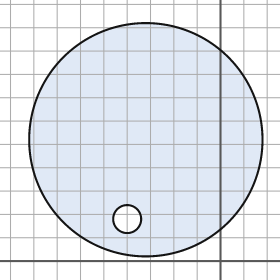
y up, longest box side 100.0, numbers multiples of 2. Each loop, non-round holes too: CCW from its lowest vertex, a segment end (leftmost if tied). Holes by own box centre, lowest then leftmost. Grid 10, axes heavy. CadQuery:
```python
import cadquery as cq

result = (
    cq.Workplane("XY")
    .moveTo(-32.0, 52.0)
    .circle(50.0)
    .moveTo(-40.0, 18.0)
    .circle(6.0)
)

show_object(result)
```